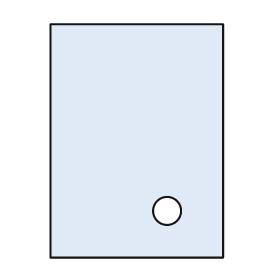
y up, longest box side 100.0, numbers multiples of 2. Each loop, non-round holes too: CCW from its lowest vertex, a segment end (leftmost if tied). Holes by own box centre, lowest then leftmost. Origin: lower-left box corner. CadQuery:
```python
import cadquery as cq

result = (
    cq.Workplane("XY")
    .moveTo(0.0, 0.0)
    .lineTo(74.0, 0.0)
    .lineTo(74.0, 100.0)
    .lineTo(0.0, 100.0)
    .close()
    .moveTo(50.0, 20.0)
    .circle(6.0)
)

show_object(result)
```